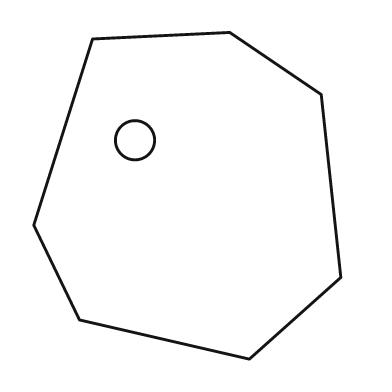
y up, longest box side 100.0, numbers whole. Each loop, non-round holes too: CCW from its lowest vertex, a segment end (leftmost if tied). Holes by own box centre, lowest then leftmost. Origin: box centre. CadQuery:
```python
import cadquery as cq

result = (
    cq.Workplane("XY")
    .moveTo(19.0, -50.0)
    .lineTo(47.0, -25.0)
    .lineTo(41.0, 31.0)
    .lineTo(13.0, 50.0)
    .lineTo(-29.0, 48.0)
    .lineTo(-47.0, -9.0)
    .lineTo(-33.0, -38.0)
    .close()
    .moveTo(-16.0, 17.0)
    .circle(6.0)
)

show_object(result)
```